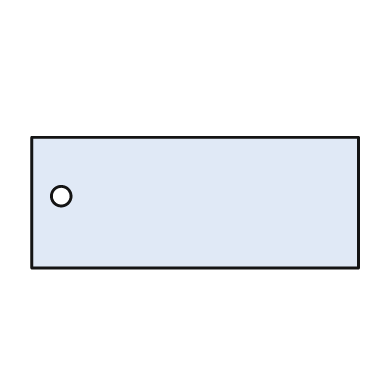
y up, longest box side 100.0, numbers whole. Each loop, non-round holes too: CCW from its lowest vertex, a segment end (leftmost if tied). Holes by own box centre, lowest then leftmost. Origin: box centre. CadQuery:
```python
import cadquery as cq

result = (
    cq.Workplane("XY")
    .moveTo(-50.0, -20.0)
    .lineTo(50.0, -20.0)
    .lineTo(50.0, 20.0)
    .lineTo(-50.0, 20.0)
    .close()
    .moveTo(-41.0, 2.0)
    .circle(3.0)
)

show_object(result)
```